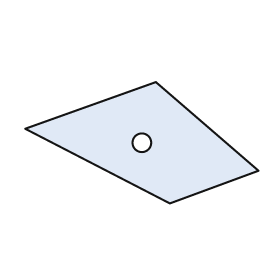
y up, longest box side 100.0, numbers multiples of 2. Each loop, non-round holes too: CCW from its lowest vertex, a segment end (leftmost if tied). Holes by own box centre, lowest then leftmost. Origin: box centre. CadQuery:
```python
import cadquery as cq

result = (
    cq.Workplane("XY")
    .moveTo(12.0, -26.0)
    .lineTo(50.0, -12.0)
    .lineTo(6.0, 26.0)
    .lineTo(-50.0, 6.0)
    .close()
    .moveTo(0.0, 0.0)
    .circle(4.0)
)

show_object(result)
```